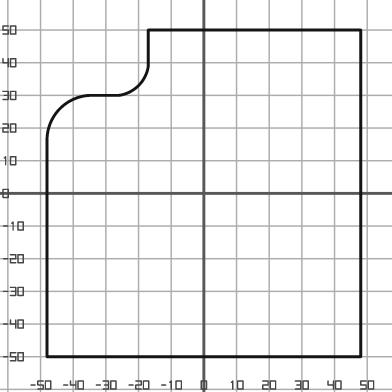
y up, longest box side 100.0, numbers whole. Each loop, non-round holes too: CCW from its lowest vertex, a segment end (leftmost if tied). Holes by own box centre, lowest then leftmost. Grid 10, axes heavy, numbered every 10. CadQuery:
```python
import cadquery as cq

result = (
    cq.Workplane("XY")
    .moveTo(-48.0, -50.0)
    .lineTo(48.0, -50.0)
    .lineTo(48.0, 50.0)
    .lineTo(-17.0, 50.0)
    .lineTo(-17.0, 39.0)
    .threePointArc((-20.0, 33.0), (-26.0, 30.0))
    .lineTo(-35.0, 30.0)
    .threePointArc((-44.0, 26.0), (-48.0, 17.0))
    .close()
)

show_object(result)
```